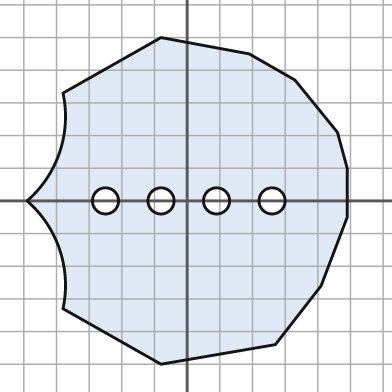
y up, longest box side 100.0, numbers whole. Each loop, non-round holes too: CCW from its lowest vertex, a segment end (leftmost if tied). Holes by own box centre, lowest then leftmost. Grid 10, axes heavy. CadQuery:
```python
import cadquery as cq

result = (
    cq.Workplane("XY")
    .moveTo(-8.0, -50.0)
    .lineTo(27.0, -44.0)
    .lineTo(41.0, -26.0)
    .lineTo(49.0, -5.0)
    .lineTo(49.0, 10.0)
    .lineTo(46.0, 21.0)
    .lineTo(33.0, 37.0)
    .lineTo(19.0, 45.0)
    .lineTo(-8.0, 50.0)
    .lineTo(-38.0, 33.0)
    .threePointArc((-39.0, 15.0), (-49.0, 0.0))
    .threePointArc((-39.0, -15.0), (-38.0, -33.0))
    .close()
    .moveTo(-25.0, 0.0)
    .circle(4.0)
    .moveTo(-8.0, 0.0)
    .circle(4.0)
    .moveTo(9.0, 0.0)
    .circle(4.0)
    .moveTo(26.0, 0.0)
    .circle(4.0)
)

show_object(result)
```